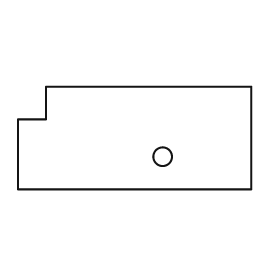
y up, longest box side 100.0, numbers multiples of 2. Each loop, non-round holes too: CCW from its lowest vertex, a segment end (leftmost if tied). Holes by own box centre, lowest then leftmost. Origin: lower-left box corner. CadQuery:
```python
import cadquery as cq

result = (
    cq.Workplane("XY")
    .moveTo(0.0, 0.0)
    .lineTo(100.0, 0.0)
    .lineTo(100.0, 44.0)
    .lineTo(12.0, 44.0)
    .lineTo(12.0, 30.0)
    .lineTo(0.0, 30.0)
    .close()
    .moveTo(62.0, 14.0)
    .circle(4.0)
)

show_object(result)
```